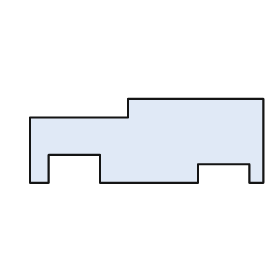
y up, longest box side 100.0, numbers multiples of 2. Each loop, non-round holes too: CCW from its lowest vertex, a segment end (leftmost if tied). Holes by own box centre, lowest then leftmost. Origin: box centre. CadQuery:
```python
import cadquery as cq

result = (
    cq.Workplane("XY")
    .moveTo(-50.0, -18.0)
    .lineTo(-42.0, -18.0)
    .lineTo(-42.0, -6.0)
    .lineTo(-20.0, -6.0)
    .lineTo(-20.0, -18.0)
    .lineTo(22.0, -18.0)
    .lineTo(22.0, -10.0)
    .lineTo(44.0, -10.0)
    .lineTo(44.0, -18.0)
    .lineTo(50.0, -18.0)
    .lineTo(50.0, 18.0)
    .lineTo(-8.0, 18.0)
    .lineTo(-8.0, 10.0)
    .lineTo(-50.0, 10.0)
    .close()
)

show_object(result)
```